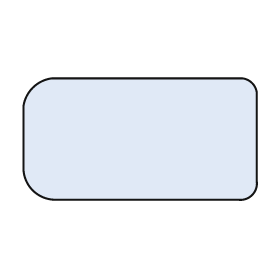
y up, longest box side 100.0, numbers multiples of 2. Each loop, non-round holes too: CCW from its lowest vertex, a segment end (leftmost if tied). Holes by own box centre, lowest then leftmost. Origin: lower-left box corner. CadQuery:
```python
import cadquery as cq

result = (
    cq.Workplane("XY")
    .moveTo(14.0, 0.0)
    .lineTo(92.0, 0.0)
    .threePointArc((98.0, 2.0), (100.0, 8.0))
    .lineTo(100.0, 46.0)
    .threePointArc((98.0, 50.0), (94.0, 52.0))
    .lineTo(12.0, 52.0)
    .threePointArc((4.0, 48.0), (0.0, 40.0))
    .lineTo(0.0, 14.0)
    .threePointArc((4.0, 4.0), (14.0, 0.0))
    .close()
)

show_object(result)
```